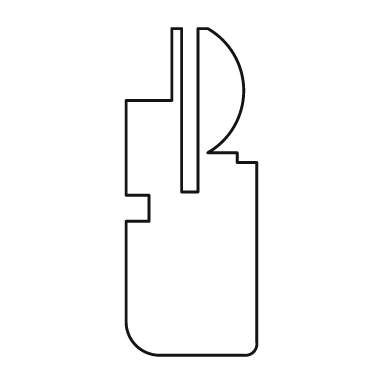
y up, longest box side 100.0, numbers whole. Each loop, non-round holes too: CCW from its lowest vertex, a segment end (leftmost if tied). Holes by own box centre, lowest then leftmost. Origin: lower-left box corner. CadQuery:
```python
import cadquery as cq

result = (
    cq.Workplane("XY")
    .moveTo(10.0, 0.0)
    .lineTo(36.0, 0.0)
    .threePointArc((39.0, 1.0), (40.0, 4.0))
    .lineTo(40.0, 59.0)
    .lineTo(34.0, 59.0)
    .lineTo(34.0, 62.0)
    .lineTo(25.0, 62.0)
    .threePointArc((36.0, 81.0), (25.0, 100.0))
    .lineTo(22.0, 100.0)
    .lineTo(22.0, 50.0)
    .lineTo(17.0, 50.0)
    .lineTo(17.0, 100.0)
    .lineTo(14.0, 100.0)
    .lineTo(14.0, 78.0)
    .lineTo(0.0, 78.0)
    .lineTo(0.0, 49.0)
    .lineTo(7.0, 49.0)
    .lineTo(7.0, 41.0)
    .lineTo(0.0, 41.0)
    .lineTo(0.0, 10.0)
    .threePointArc((3.0, 3.0), (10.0, 0.0))
    .close()
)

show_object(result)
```